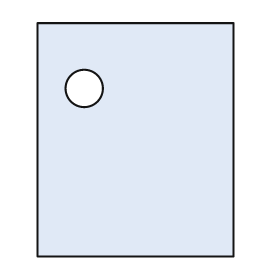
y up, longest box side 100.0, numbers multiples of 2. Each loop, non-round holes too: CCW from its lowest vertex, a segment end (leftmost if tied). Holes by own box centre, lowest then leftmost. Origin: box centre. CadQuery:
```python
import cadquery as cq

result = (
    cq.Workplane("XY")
    .moveTo(-42.0, -50.0)
    .lineTo(42.0, -50.0)
    .lineTo(42.0, 50.0)
    .lineTo(-42.0, 50.0)
    .close()
    .moveTo(-22.0, 22.0)
    .circle(8.0)
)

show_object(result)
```